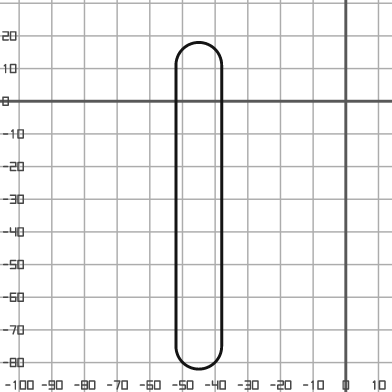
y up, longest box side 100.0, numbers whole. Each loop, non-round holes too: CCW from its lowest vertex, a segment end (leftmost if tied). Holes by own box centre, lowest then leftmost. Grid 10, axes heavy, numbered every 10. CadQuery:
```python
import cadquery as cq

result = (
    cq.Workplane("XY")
    .moveTo(-52.0, -75.0)
    .threePointArc((-45.0, -82.0), (-38.0, -75.0))
    .lineTo(-38.0, 11.0)
    .threePointArc((-45.0, 18.0), (-52.0, 11.0))
    .close()
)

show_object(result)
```